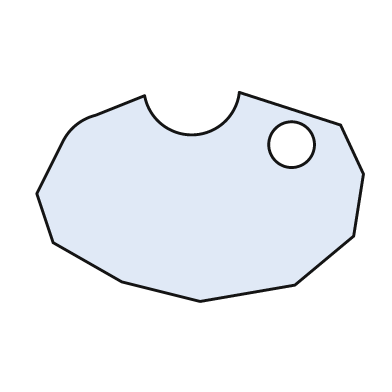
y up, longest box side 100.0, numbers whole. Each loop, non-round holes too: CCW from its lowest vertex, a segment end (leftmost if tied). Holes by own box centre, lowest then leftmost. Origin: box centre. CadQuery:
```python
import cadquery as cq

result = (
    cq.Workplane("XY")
    .moveTo(0.0, -32.0)
    .lineTo(29.0, -27.0)
    .lineTo(47.0, -12.0)
    .lineTo(50.0, 7.0)
    .lineTo(43.0, 22.0)
    .lineTo(12.0, 32.0)
    .threePointArc((-2.0, 19.0), (-17.0, 31.0))
    .lineTo(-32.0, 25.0)
    .threePointArc((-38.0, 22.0), (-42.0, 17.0))
    .lineTo(-50.0, 1.0)
    .lineTo(-45.0, -14.0)
    .lineTo(-24.0, -26.0)
    .close()
    .moveTo(28.0, 16.0)
    .circle(7.0)
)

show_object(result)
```